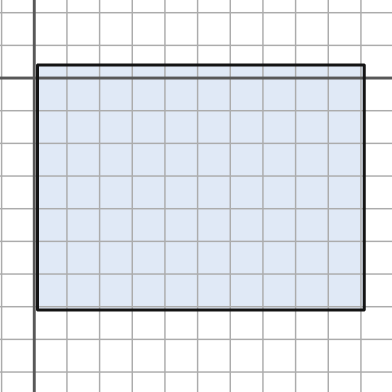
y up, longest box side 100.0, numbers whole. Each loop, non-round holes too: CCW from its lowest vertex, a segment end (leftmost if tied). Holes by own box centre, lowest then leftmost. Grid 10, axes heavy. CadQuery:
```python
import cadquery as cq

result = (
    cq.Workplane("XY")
    .moveTo(1.0, -71.0)
    .lineTo(101.0, -71.0)
    .lineTo(101.0, 4.0)
    .lineTo(1.0, 4.0)
    .close()
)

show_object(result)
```